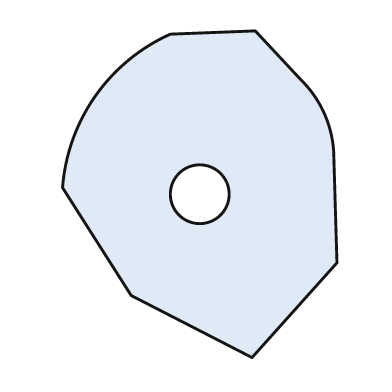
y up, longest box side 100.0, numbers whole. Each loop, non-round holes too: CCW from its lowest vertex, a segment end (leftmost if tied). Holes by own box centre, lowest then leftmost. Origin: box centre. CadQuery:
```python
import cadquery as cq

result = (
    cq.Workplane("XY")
    .moveTo(16.0, -50.0)
    .lineTo(42.0, -21.0)
    .lineTo(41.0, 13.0)
    .threePointArc((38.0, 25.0), (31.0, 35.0))
    .lineTo(17.0, 50.0)
    .lineTo(-9.0, 49.0)
    .threePointArc((-32.0, 30.0), (-42.0, 2.0))
    .lineTo(-21.0, -31.0)
    .close()
    .moveTo(0.0, 0.0)
    .circle(9.0)
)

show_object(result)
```